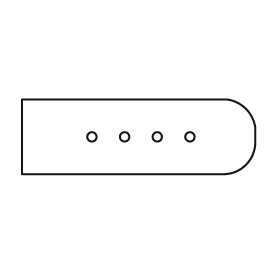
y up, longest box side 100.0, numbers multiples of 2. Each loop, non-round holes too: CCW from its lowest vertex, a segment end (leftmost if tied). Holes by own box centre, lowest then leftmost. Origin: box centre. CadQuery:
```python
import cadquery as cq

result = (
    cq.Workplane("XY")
    .moveTo(-50.0, -16.0)
    .lineTo(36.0, -16.0)
    .threePointArc((46.0, -12.0), (50.0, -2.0))
    .lineTo(50.0, 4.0)
    .threePointArc((46.0, 12.0), (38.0, 16.0))
    .lineTo(-50.0, 16.0)
    .close()
    .moveTo(-20.0, 0.0)
    .circle(2.0)
    .moveTo(-6.0, 0.0)
    .circle(2.0)
    .moveTo(8.0, 0.0)
    .circle(2.0)
    .moveTo(22.0, 0.0)
    .circle(2.0)
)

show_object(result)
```